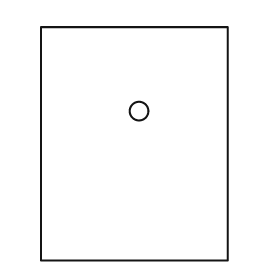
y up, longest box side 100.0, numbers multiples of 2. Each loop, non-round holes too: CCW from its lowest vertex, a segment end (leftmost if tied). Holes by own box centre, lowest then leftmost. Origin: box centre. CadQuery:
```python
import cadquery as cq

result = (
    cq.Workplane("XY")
    .moveTo(-40.0, -50.0)
    .lineTo(40.0, -50.0)
    .lineTo(40.0, 50.0)
    .lineTo(-40.0, 50.0)
    .close()
    .moveTo(2.0, 14.0)
    .circle(4.0)
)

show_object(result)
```